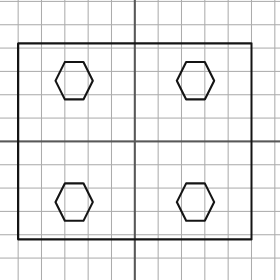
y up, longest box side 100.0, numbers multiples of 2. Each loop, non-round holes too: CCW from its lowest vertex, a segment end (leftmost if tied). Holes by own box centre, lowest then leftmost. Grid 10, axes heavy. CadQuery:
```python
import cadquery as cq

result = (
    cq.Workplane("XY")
    .moveTo(-50.0, -42.0)
    .lineTo(50.0, -42.0)
    .lineTo(50.0, 42.0)
    .lineTo(-50.0, 42.0)
    .close()
    .moveTo(-30.0, -34.0)
    .lineTo(-22.0, -34.0)
    .lineTo(-18.0, -26.0)
    .lineTo(-22.0, -18.0)
    .lineTo(-30.0, -18.0)
    .lineTo(-34.0, -26.0)
    .close()
    .moveTo(22.0, -34.0)
    .lineTo(30.0, -34.0)
    .lineTo(34.0, -26.0)
    .lineTo(30.0, -18.0)
    .lineTo(22.0, -18.0)
    .lineTo(18.0, -26.0)
    .close()
    .moveTo(-30.0, 18.0)
    .lineTo(-22.0, 18.0)
    .lineTo(-18.0, 26.0)
    .lineTo(-22.0, 34.0)
    .lineTo(-30.0, 34.0)
    .lineTo(-34.0, 26.0)
    .close()
    .moveTo(22.0, 18.0)
    .lineTo(30.0, 18.0)
    .lineTo(34.0, 26.0)
    .lineTo(30.0, 34.0)
    .lineTo(22.0, 34.0)
    .lineTo(18.0, 26.0)
    .close()
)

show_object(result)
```